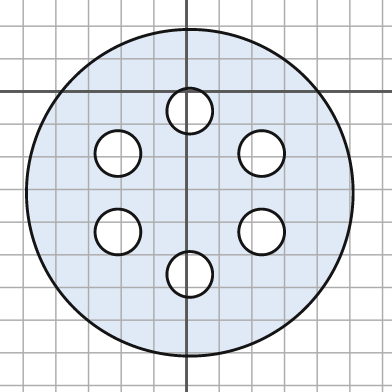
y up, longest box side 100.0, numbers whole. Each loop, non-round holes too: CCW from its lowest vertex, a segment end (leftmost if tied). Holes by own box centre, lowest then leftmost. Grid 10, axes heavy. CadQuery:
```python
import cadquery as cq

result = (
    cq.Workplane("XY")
    .moveTo(1.0, -31.0)
    .circle(50.0)
    .moveTo(1.0, -56.0)
    .circle(7.0)
    .moveTo(-21.0, -43.0)
    .circle(7.0)
    .moveTo(23.0, -43.0)
    .circle(7.0)
    .moveTo(-21.0, -19.0)
    .circle(7.0)
    .moveTo(23.0, -19.0)
    .circle(7.0)
    .moveTo(1.0, -6.0)
    .circle(7.0)
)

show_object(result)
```